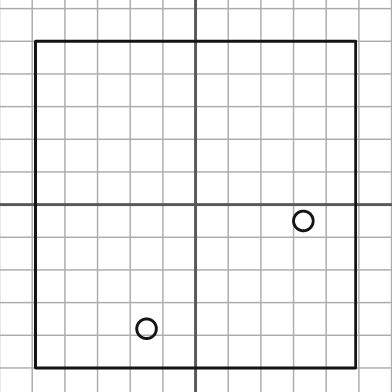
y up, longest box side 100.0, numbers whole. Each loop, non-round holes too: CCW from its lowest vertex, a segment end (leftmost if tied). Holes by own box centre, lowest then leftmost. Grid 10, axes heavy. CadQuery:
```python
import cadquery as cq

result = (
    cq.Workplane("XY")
    .moveTo(-49.0, -50.0)
    .lineTo(49.0, -50.0)
    .lineTo(49.0, 50.0)
    .lineTo(-49.0, 50.0)
    .close()
    .moveTo(-15.0, -38.0)
    .circle(3.0)
    .moveTo(33.0, -5.0)
    .circle(3.0)
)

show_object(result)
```